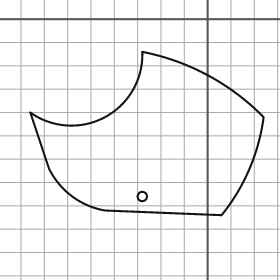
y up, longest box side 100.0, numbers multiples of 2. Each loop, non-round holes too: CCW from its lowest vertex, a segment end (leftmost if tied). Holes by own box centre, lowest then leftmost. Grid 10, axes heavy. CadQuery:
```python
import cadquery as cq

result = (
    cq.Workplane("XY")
    .moveTo(6.0, -84.0)
    .threePointArc((18.0, -64.0), (24.0, -42.0))
    .threePointArc((0.0, -24.0), (-28.0, -14.0))
    .threePointArc((-44.0, -42.0), (-76.0, -40.0))
    .lineTo(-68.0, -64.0)
    .threePointArc((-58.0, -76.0), (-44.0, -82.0))
    .close()
    .moveTo(-28.0, -76.0)
    .circle(2.0)
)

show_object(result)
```